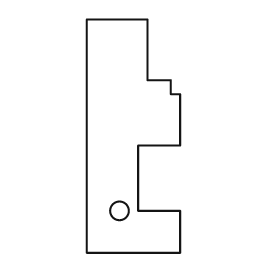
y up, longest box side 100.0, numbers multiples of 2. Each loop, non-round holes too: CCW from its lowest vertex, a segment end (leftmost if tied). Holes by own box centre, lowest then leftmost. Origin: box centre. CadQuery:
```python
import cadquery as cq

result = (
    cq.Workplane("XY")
    .moveTo(-20.0, -50.0)
    .lineTo(20.0, -50.0)
    .lineTo(20.0, -32.0)
    .lineTo(2.0, -32.0)
    .lineTo(2.0, -4.0)
    .lineTo(20.0, -4.0)
    .lineTo(20.0, 18.0)
    .lineTo(16.0, 18.0)
    .lineTo(16.0, 24.0)
    .lineTo(6.0, 24.0)
    .lineTo(6.0, 50.0)
    .lineTo(-20.0, 50.0)
    .close()
    .moveTo(-6.0, -32.0)
    .circle(4.0)
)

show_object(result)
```